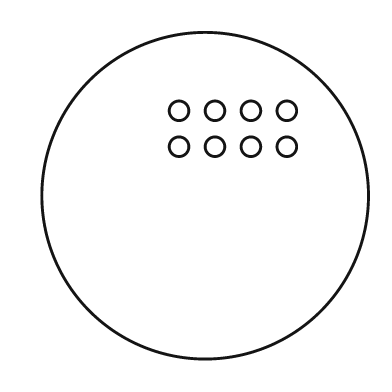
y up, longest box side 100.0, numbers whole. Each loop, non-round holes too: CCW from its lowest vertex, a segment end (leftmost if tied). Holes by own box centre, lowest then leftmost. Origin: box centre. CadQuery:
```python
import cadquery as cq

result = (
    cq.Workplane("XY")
    .moveTo(0.0, 0.0)
    .circle(50.0)
    .moveTo(-8.0, 15.0)
    .circle(3.0)
    .moveTo(3.0, 15.0)
    .circle(3.0)
    .moveTo(14.0, 15.0)
    .circle(3.0)
    .moveTo(25.0, 15.0)
    .circle(3.0)
    .moveTo(-8.0, 26.0)
    .circle(3.0)
    .moveTo(3.0, 26.0)
    .circle(3.0)
    .moveTo(14.0, 26.0)
    .circle(3.0)
    .moveTo(25.0, 26.0)
    .circle(3.0)
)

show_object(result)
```